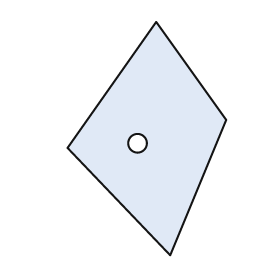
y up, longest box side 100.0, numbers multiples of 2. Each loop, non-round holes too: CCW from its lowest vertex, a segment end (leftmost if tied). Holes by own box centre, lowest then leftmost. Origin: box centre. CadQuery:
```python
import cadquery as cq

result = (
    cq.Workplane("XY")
    .moveTo(10.0, -50.0)
    .lineTo(34.0, 8.0)
    .lineTo(4.0, 50.0)
    .lineTo(-34.0, -4.0)
    .close()
    .moveTo(-4.0, -2.0)
    .circle(4.0)
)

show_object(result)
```